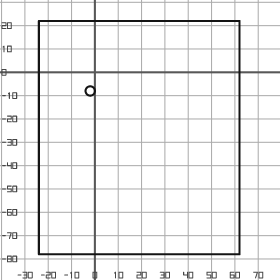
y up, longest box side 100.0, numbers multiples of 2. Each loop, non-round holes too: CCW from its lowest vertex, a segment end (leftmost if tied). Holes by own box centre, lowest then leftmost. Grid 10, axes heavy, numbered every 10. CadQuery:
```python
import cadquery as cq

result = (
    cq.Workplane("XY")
    .moveTo(-24.0, -78.0)
    .lineTo(62.0, -78.0)
    .lineTo(62.0, 22.0)
    .lineTo(-24.0, 22.0)
    .close()
    .moveTo(-2.0, -8.0)
    .circle(2.0)
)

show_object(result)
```